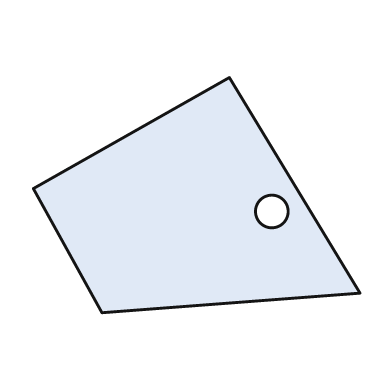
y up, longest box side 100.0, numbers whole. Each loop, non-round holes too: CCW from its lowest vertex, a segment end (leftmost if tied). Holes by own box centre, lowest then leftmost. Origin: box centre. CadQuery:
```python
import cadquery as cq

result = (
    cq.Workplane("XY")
    .moveTo(-29.0, -36.0)
    .lineTo(50.0, -30.0)
    .lineTo(10.0, 36.0)
    .lineTo(-50.0, 2.0)
    .close()
    .moveTo(23.0, -5.0)
    .circle(5.0)
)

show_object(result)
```